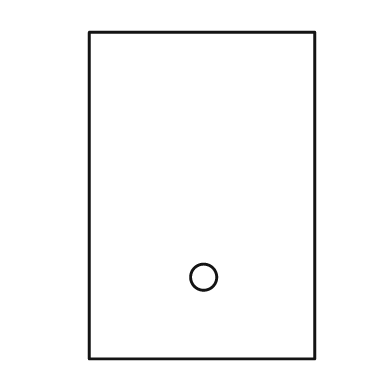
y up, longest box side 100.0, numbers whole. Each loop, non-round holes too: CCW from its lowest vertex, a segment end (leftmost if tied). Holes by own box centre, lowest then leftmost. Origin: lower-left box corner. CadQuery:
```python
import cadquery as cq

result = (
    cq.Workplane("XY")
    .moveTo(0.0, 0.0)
    .lineTo(69.0, 0.0)
    .lineTo(69.0, 100.0)
    .lineTo(0.0, 100.0)
    .close()
    .moveTo(35.0, 25.0)
    .circle(4.0)
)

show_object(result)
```